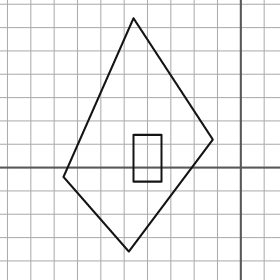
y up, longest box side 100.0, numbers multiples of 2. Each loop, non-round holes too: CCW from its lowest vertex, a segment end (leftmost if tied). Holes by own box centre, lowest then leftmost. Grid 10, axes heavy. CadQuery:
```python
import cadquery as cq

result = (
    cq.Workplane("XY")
    .moveTo(-48.0, -36.0)
    .lineTo(-12.0, 12.0)
    .lineTo(-46.0, 64.0)
    .lineTo(-76.0, -4.0)
    .close()
    .moveTo(-46.0, -6.0)
    .lineTo(-34.0, -6.0)
    .lineTo(-34.0, 14.0)
    .lineTo(-46.0, 14.0)
    .close()
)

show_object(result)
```